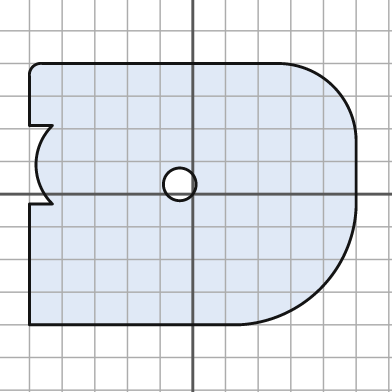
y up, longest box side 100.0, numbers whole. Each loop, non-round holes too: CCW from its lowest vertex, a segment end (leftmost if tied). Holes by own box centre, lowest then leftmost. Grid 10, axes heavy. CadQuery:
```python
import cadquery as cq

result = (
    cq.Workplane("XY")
    .moveTo(-50.0, -40.0)
    .lineTo(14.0, -40.0)
    .threePointArc((39.0, -29.0), (50.0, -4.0))
    .lineTo(50.0, 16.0)
    .threePointArc((43.0, 33.0), (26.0, 40.0))
    .lineTo(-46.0, 40.0)
    .threePointArc((-49.0, 39.0), (-50.0, 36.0))
    .lineTo(-50.0, 21.0)
    .lineTo(-43.0, 21.0)
    .threePointArc((-48.0, 9.0), (-43.0, -3.0))
    .lineTo(-50.0, -3.0)
    .close()
    .moveTo(-4.0, 3.0)
    .circle(5.0)
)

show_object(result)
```